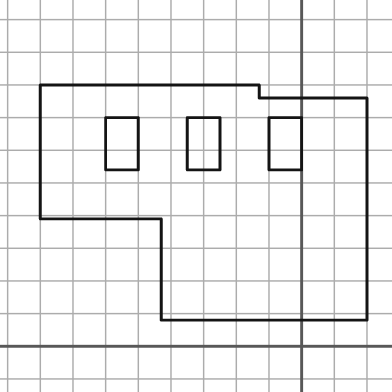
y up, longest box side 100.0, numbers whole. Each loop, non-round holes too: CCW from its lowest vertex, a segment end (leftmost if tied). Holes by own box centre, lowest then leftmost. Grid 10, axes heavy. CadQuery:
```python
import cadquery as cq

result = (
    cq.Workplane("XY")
    .moveTo(-43.0, 8.0)
    .lineTo(20.0, 8.0)
    .lineTo(20.0, 76.0)
    .lineTo(-13.0, 76.0)
    .lineTo(-13.0, 80.0)
    .lineTo(-80.0, 80.0)
    .lineTo(-80.0, 39.0)
    .lineTo(-43.0, 39.0)
    .close()
    .moveTo(-60.0, 54.0)
    .lineTo(-50.0, 54.0)
    .lineTo(-50.0, 70.0)
    .lineTo(-60.0, 70.0)
    .close()
    .moveTo(-35.0, 54.0)
    .lineTo(-25.0, 54.0)
    .lineTo(-25.0, 70.0)
    .lineTo(-35.0, 70.0)
    .close()
    .moveTo(-10.0, 54.0)
    .lineTo(0.0, 54.0)
    .lineTo(0.0, 70.0)
    .lineTo(-10.0, 70.0)
    .close()
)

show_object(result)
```